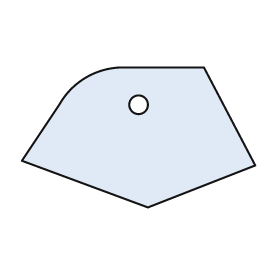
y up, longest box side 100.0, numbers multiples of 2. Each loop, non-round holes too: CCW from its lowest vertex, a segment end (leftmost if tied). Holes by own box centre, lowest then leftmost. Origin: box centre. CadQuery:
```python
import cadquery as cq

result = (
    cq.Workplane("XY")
    .moveTo(4.0, -30.0)
    .lineTo(50.0, -12.0)
    .lineTo(28.0, 30.0)
    .lineTo(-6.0, 30.0)
    .threePointArc((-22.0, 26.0), (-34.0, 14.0))
    .lineTo(-50.0, -10.0)
    .close()
    .moveTo(0.0, 14.0)
    .circle(4.0)
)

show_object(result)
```